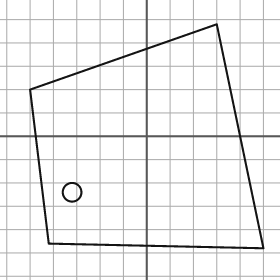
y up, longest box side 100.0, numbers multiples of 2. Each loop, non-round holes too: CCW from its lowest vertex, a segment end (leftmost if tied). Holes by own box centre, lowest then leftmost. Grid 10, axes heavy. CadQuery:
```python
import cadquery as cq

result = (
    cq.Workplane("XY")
    .moveTo(50.0, -48.0)
    .lineTo(30.0, 48.0)
    .lineTo(-50.0, 20.0)
    .lineTo(-42.0, -46.0)
    .close()
    .moveTo(-32.0, -24.0)
    .circle(4.0)
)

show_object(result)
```